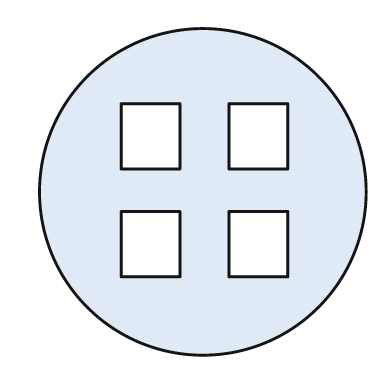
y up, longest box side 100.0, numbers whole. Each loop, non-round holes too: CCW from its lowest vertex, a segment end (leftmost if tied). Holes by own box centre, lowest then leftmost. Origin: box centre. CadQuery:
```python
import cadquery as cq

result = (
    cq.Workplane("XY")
    .moveTo(0.0, 0.0)
    .circle(50.0)
    .moveTo(-25.0, -26.0)
    .lineTo(-7.0, -26.0)
    .lineTo(-7.0, -6.0)
    .lineTo(-25.0, -6.0)
    .close()
    .moveTo(8.0, -26.0)
    .lineTo(26.0, -26.0)
    .lineTo(26.0, -6.0)
    .lineTo(8.0, -6.0)
    .close()
    .moveTo(-25.0, 7.0)
    .lineTo(-7.0, 7.0)
    .lineTo(-7.0, 27.0)
    .lineTo(-25.0, 27.0)
    .close()
    .moveTo(8.0, 7.0)
    .lineTo(26.0, 7.0)
    .lineTo(26.0, 27.0)
    .lineTo(8.0, 27.0)
    .close()
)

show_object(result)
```